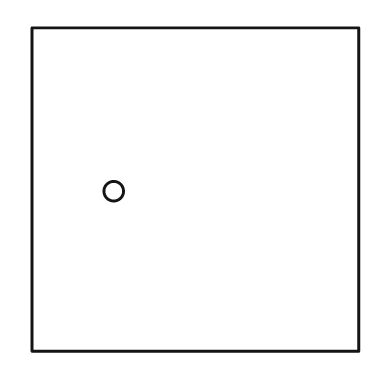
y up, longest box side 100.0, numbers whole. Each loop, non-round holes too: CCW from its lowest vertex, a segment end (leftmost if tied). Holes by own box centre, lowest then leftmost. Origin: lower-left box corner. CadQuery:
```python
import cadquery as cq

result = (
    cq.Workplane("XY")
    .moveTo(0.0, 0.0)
    .lineTo(100.0, 0.0)
    .lineTo(100.0, 99.0)
    .lineTo(0.0, 99.0)
    .close()
    .moveTo(25.0, 49.0)
    .circle(3.0)
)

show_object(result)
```